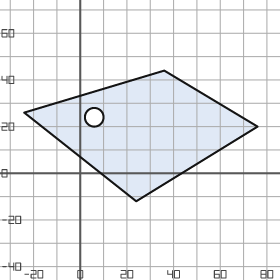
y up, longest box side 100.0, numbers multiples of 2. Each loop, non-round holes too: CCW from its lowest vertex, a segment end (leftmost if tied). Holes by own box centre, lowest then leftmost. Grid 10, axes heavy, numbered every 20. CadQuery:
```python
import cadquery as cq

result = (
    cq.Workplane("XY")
    .moveTo(24.0, -12.0)
    .lineTo(76.0, 20.0)
    .lineTo(36.0, 44.0)
    .lineTo(-24.0, 26.0)
    .close()
    .moveTo(6.0, 24.0)
    .circle(4.0)
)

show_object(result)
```